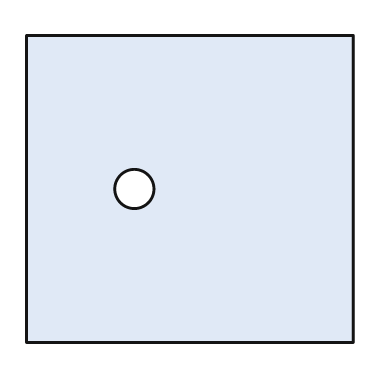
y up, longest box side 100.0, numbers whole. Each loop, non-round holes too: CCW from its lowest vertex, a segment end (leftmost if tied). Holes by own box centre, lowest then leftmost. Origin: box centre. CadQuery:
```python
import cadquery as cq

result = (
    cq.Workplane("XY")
    .moveTo(-50.0, -47.0)
    .lineTo(50.0, -47.0)
    .lineTo(50.0, 47.0)
    .lineTo(-50.0, 47.0)
    .close()
    .moveTo(-17.0, 0.0)
    .circle(6.0)
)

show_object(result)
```